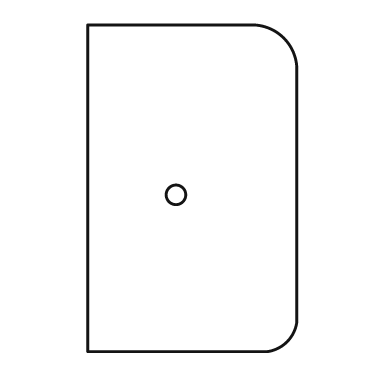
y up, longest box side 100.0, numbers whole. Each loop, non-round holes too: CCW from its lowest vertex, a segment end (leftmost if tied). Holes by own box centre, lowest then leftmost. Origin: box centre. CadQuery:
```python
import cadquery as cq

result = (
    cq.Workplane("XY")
    .moveTo(-32.0, -50.0)
    .lineTo(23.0, -50.0)
    .threePointArc((29.0, -47.0), (32.0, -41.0))
    .lineTo(32.0, 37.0)
    .threePointArc((28.0, 46.0), (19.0, 50.0))
    .lineTo(-32.0, 50.0)
    .close()
    .moveTo(-5.0, -2.0)
    .circle(3.0)
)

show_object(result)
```